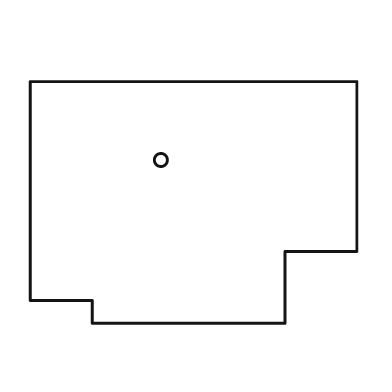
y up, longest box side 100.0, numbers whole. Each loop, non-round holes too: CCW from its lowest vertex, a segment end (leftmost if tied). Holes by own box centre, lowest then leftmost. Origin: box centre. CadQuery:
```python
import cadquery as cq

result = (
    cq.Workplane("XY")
    .moveTo(-31.0, -37.0)
    .lineTo(28.0, -37.0)
    .lineTo(28.0, -15.0)
    .lineTo(50.0, -15.0)
    .lineTo(50.0, 37.0)
    .lineTo(-50.0, 37.0)
    .lineTo(-50.0, -30.0)
    .lineTo(-31.0, -30.0)
    .close()
    .moveTo(-10.0, 13.0)
    .circle(2.0)
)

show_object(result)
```